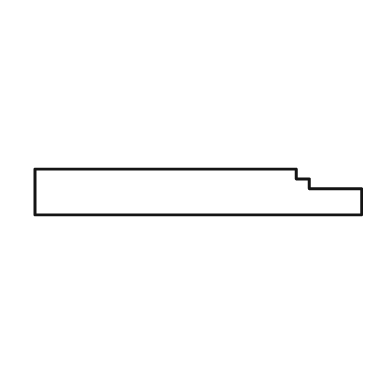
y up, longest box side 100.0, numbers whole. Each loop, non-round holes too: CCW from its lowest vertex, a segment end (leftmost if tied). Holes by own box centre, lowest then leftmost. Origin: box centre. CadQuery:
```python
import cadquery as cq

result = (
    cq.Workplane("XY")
    .moveTo(-50.0, -7.0)
    .lineTo(50.0, -7.0)
    .lineTo(50.0, 1.0)
    .lineTo(34.0, 1.0)
    .lineTo(34.0, 4.0)
    .lineTo(30.0, 4.0)
    .lineTo(30.0, 7.0)
    .lineTo(-50.0, 7.0)
    .close()
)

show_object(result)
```